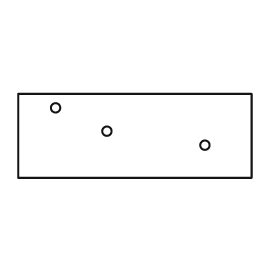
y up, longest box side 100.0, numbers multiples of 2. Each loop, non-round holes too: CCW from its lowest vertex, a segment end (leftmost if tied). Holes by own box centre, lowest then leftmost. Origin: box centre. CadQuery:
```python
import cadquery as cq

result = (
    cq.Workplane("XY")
    .moveTo(-50.0, -18.0)
    .lineTo(50.0, -18.0)
    .lineTo(50.0, 18.0)
    .lineTo(-50.0, 18.0)
    .close()
    .moveTo(30.0, -4.0)
    .circle(2.0)
    .moveTo(-12.0, 2.0)
    .circle(2.0)
    .moveTo(-34.0, 12.0)
    .circle(2.0)
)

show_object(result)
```